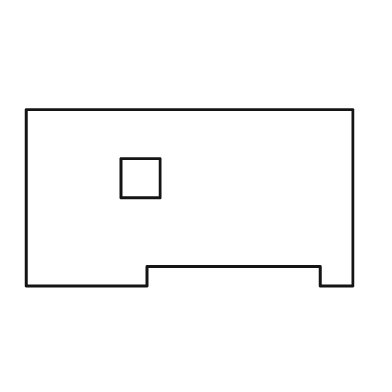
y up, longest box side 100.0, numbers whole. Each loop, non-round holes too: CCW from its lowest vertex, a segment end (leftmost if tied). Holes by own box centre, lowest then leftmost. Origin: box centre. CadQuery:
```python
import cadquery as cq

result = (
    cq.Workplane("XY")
    .moveTo(-50.0, -27.0)
    .lineTo(-13.0, -27.0)
    .lineTo(-13.0, -21.0)
    .lineTo(40.0, -21.0)
    .lineTo(40.0, -27.0)
    .lineTo(50.0, -27.0)
    .lineTo(50.0, 27.0)
    .lineTo(-50.0, 27.0)
    .close()
    .moveTo(-21.0, 0.0)
    .lineTo(-9.0, 0.0)
    .lineTo(-9.0, 12.0)
    .lineTo(-21.0, 12.0)
    .close()
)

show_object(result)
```